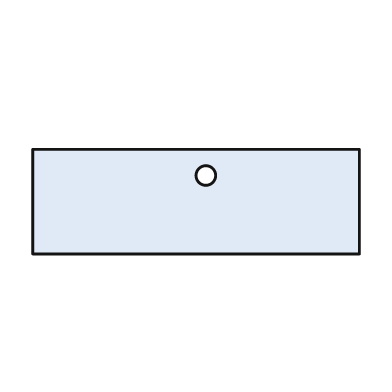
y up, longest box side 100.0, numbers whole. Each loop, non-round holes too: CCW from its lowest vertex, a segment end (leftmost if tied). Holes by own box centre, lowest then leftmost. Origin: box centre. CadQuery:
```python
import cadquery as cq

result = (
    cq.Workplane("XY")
    .moveTo(-50.0, -16.0)
    .lineTo(50.0, -16.0)
    .lineTo(50.0, 16.0)
    .lineTo(-50.0, 16.0)
    .close()
    .moveTo(3.0, 8.0)
    .circle(3.0)
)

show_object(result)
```